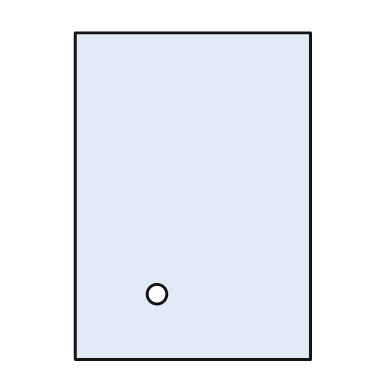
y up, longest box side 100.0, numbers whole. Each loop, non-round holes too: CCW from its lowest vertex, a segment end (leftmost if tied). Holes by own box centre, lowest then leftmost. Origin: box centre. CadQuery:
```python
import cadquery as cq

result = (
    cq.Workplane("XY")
    .moveTo(-36.0, -50.0)
    .lineTo(36.0, -50.0)
    .lineTo(36.0, 50.0)
    .lineTo(-36.0, 50.0)
    .close()
    .moveTo(-11.0, -30.0)
    .circle(3.0)
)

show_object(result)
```